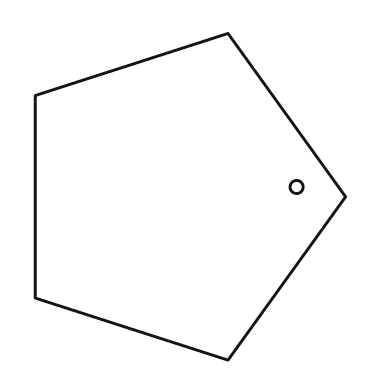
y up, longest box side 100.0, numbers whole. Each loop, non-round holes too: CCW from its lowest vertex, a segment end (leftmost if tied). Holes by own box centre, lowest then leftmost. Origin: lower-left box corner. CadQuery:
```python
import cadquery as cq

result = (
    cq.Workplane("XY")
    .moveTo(59.0, 0.0)
    .lineTo(95.0, 50.0)
    .lineTo(59.0, 100.0)
    .lineTo(0.0, 81.0)
    .lineTo(0.0, 19.0)
    .close()
    .moveTo(80.0, 53.0)
    .circle(2.0)
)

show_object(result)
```